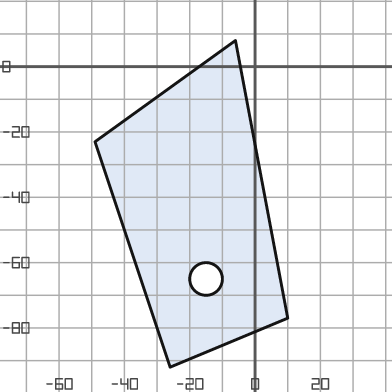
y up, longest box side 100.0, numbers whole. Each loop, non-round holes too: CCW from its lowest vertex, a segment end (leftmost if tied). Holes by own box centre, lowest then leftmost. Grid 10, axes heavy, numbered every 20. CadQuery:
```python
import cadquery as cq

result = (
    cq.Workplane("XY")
    .moveTo(-26.0, -92.0)
    .lineTo(10.0, -77.0)
    .lineTo(-6.0, 8.0)
    .lineTo(-49.0, -23.0)
    .close()
    .moveTo(-15.0, -65.0)
    .circle(5.0)
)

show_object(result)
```